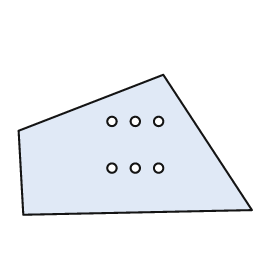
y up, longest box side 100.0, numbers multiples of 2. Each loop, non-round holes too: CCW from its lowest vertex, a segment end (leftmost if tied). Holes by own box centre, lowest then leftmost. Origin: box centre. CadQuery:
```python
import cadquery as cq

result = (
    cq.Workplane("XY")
    .moveTo(-48.0, -30.0)
    .lineTo(50.0, -28.0)
    .lineTo(12.0, 30.0)
    .lineTo(-50.0, 6.0)
    .close()
    .moveTo(-10.0, -10.0)
    .circle(2.0)
    .moveTo(0.0, -10.0)
    .circle(2.0)
    .moveTo(10.0, -10.0)
    .circle(2.0)
    .moveTo(-10.0, 10.0)
    .circle(2.0)
    .moveTo(0.0, 10.0)
    .circle(2.0)
    .moveTo(10.0, 10.0)
    .circle(2.0)
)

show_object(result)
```